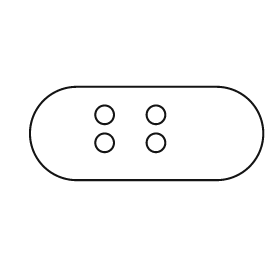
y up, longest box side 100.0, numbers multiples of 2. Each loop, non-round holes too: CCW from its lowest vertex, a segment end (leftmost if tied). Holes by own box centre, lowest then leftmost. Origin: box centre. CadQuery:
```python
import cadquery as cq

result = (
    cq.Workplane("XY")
    .moveTo(-30.0, -20.0)
    .lineTo(30.0, -20.0)
    .threePointArc((50.0, 0.0), (30.0, 20.0))
    .lineTo(-30.0, 20.0)
    .threePointArc((-50.0, 0.0), (-30.0, -20.0))
    .close()
    .moveTo(-18.0, -4.0)
    .circle(4.0)
    .moveTo(4.0, -4.0)
    .circle(4.0)
    .moveTo(-18.0, 8.0)
    .circle(4.0)
    .moveTo(4.0, 8.0)
    .circle(4.0)
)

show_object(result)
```